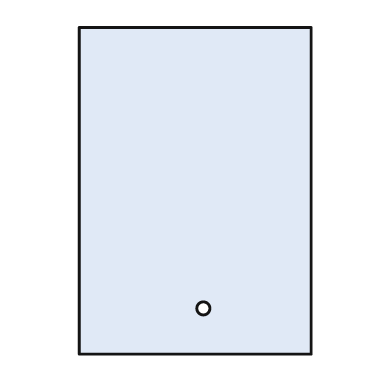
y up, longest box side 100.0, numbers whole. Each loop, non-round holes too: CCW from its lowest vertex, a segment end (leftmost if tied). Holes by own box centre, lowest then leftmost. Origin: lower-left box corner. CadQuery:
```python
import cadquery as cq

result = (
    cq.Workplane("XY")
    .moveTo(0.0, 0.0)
    .lineTo(71.0, 0.0)
    .lineTo(71.0, 100.0)
    .lineTo(0.0, 100.0)
    .close()
    .moveTo(38.0, 14.0)
    .circle(2.0)
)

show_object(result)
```